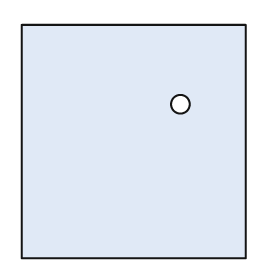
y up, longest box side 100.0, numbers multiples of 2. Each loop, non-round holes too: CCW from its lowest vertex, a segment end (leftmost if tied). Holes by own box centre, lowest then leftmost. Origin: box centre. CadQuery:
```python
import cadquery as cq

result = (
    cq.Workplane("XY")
    .moveTo(-48.0, -50.0)
    .lineTo(48.0, -50.0)
    .lineTo(48.0, 50.0)
    .lineTo(-48.0, 50.0)
    .close()
    .moveTo(20.0, 16.0)
    .circle(4.0)
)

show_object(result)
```